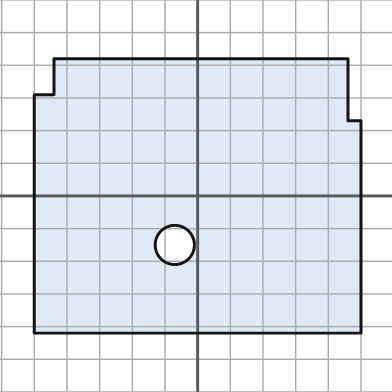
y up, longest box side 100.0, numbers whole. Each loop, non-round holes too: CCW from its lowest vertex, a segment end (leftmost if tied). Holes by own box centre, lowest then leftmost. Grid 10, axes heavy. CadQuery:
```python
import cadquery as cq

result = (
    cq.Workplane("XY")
    .moveTo(-50.0, -42.0)
    .lineTo(50.0, -42.0)
    .lineTo(50.0, 23.0)
    .lineTo(46.0, 23.0)
    .lineTo(46.0, 42.0)
    .lineTo(-44.0, 42.0)
    .lineTo(-44.0, 31.0)
    .lineTo(-50.0, 31.0)
    .close()
    .moveTo(-7.0, -15.0)
    .circle(6.0)
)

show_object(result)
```